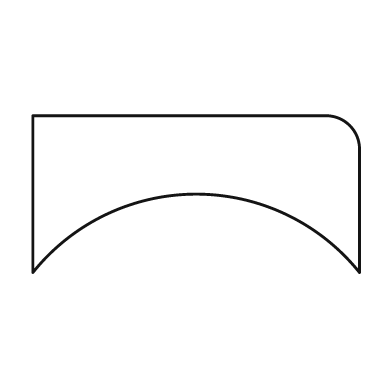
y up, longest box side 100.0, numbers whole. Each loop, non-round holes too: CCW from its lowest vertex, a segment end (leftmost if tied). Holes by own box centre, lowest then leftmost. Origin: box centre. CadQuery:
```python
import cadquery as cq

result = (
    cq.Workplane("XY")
    .moveTo(-50.0, -24.0)
    .threePointArc((0.0, 0.0), (50.0, -24.0))
    .lineTo(50.0, 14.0)
    .threePointArc((47.0, 21.0), (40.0, 24.0))
    .lineTo(-50.0, 24.0)
    .close()
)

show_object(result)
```